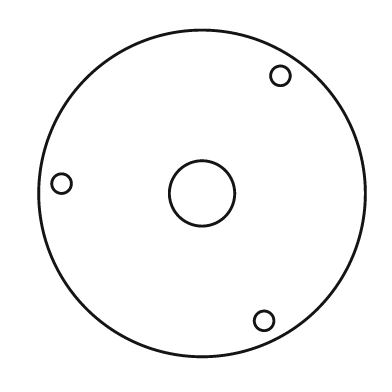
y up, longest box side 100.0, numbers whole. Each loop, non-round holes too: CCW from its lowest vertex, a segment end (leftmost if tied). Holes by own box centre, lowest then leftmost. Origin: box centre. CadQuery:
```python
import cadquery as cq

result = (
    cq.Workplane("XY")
    .moveTo(0.0, 0.0)
    .circle(50.0)
    .moveTo(19.0, -39.0)
    .circle(3.0)
    .moveTo(0.0, 0.0)
    .circle(10.0)
    .moveTo(-43.0, 3.0)
    .circle(3.0)
    .moveTo(24.0, 36.0)
    .circle(3.0)
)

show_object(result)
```